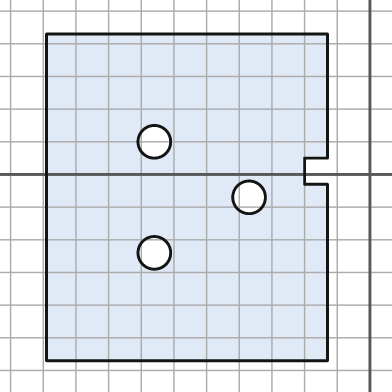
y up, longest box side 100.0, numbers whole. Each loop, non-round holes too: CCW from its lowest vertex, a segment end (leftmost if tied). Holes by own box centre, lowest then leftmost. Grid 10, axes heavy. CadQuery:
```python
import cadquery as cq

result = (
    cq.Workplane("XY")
    .moveTo(-99.0, -57.0)
    .lineTo(-13.0, -57.0)
    .lineTo(-13.0, -3.0)
    .lineTo(-20.0, -3.0)
    .lineTo(-20.0, 5.0)
    .lineTo(-13.0, 5.0)
    .lineTo(-13.0, 43.0)
    .lineTo(-99.0, 43.0)
    .close()
    .moveTo(-66.0, -24.0)
    .circle(5.0)
    .moveTo(-37.0, -7.0)
    .circle(5.0)
    .moveTo(-66.0, 10.0)
    .circle(5.0)
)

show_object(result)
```